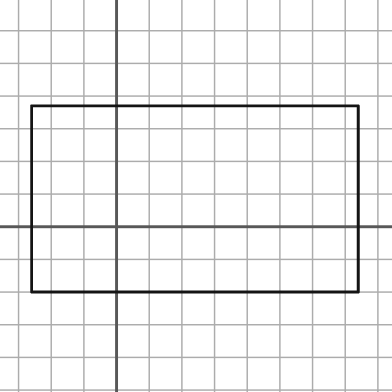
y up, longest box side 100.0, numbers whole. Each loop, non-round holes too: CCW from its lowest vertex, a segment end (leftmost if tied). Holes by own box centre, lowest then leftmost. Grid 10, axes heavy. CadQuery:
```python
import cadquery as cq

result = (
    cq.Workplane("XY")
    .moveTo(-26.0, -20.0)
    .lineTo(74.0, -20.0)
    .lineTo(74.0, 37.0)
    .lineTo(-26.0, 37.0)
    .close()
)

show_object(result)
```